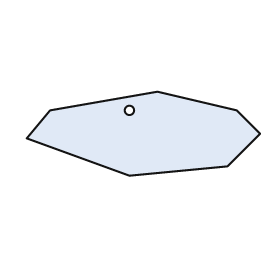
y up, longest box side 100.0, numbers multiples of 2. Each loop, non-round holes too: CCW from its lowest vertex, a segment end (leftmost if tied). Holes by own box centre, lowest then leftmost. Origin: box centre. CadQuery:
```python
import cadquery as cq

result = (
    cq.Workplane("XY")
    .moveTo(-6.0, -18.0)
    .lineTo(36.0, -14.0)
    .lineTo(50.0, 0.0)
    .lineTo(40.0, 10.0)
    .lineTo(6.0, 18.0)
    .lineTo(-40.0, 10.0)
    .lineTo(-50.0, -2.0)
    .close()
    .moveTo(-6.0, 10.0)
    .circle(2.0)
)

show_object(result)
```